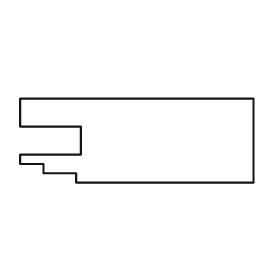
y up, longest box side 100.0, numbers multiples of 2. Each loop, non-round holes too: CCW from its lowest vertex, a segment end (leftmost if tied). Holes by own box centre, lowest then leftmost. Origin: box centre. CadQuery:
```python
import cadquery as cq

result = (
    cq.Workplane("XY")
    .moveTo(-26.0, -18.0)
    .lineTo(50.0, -18.0)
    .lineTo(50.0, 18.0)
    .lineTo(-50.0, 18.0)
    .lineTo(-50.0, 6.0)
    .lineTo(-24.0, 6.0)
    .lineTo(-24.0, -6.0)
    .lineTo(-50.0, -6.0)
    .lineTo(-50.0, -10.0)
    .lineTo(-40.0, -10.0)
    .lineTo(-40.0, -14.0)
    .lineTo(-26.0, -14.0)
    .close()
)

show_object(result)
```